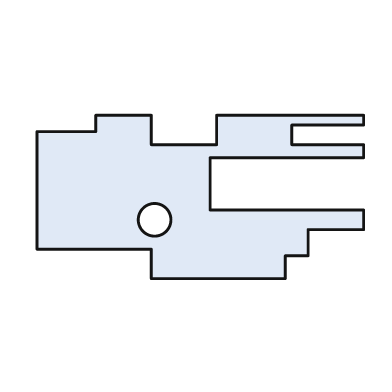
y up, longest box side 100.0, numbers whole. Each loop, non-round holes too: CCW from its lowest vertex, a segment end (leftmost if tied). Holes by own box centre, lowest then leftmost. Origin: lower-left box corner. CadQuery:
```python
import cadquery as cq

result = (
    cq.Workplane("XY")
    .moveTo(35.0, 0.0)
    .lineTo(76.0, 0.0)
    .lineTo(76.0, 7.0)
    .lineTo(83.0, 7.0)
    .lineTo(83.0, 15.0)
    .lineTo(100.0, 15.0)
    .lineTo(100.0, 21.0)
    .lineTo(53.0, 21.0)
    .lineTo(53.0, 37.0)
    .lineTo(100.0, 37.0)
    .lineTo(100.0, 41.0)
    .lineTo(78.0, 41.0)
    .lineTo(78.0, 47.0)
    .lineTo(100.0, 47.0)
    .lineTo(100.0, 50.0)
    .lineTo(55.0, 50.0)
    .lineTo(55.0, 41.0)
    .lineTo(35.0, 41.0)
    .lineTo(35.0, 50.0)
    .lineTo(18.0, 50.0)
    .lineTo(18.0, 45.0)
    .lineTo(0.0, 45.0)
    .lineTo(0.0, 9.0)
    .lineTo(35.0, 9.0)
    .close()
    .moveTo(36.0, 18.0)
    .circle(5.0)
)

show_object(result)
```